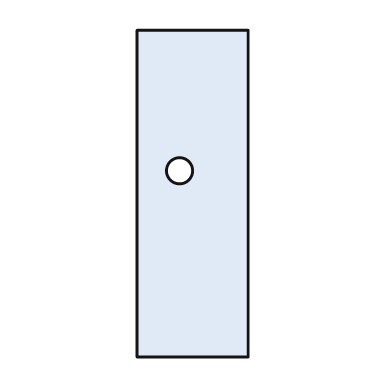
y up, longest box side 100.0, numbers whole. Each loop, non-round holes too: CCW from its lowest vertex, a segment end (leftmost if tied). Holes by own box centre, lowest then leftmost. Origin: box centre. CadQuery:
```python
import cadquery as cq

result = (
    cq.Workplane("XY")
    .moveTo(-17.0, -50.0)
    .lineTo(17.0, -50.0)
    .lineTo(17.0, 50.0)
    .lineTo(-17.0, 50.0)
    .close()
    .moveTo(-4.0, 7.0)
    .circle(4.0)
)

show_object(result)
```